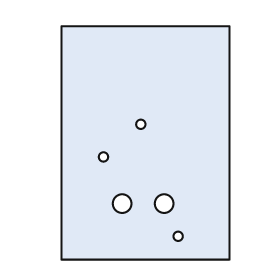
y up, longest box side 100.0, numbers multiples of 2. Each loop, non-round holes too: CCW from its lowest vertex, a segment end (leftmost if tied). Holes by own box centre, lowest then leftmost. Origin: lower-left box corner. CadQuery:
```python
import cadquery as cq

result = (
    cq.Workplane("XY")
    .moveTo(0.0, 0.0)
    .lineTo(72.0, 0.0)
    .lineTo(72.0, 100.0)
    .lineTo(0.0, 100.0)
    .close()
    .moveTo(50.0, 10.0)
    .circle(2.0)
    .moveTo(26.0, 24.0)
    .circle(4.0)
    .moveTo(44.0, 24.0)
    .circle(4.0)
    .moveTo(18.0, 44.0)
    .circle(2.0)
    .moveTo(34.0, 58.0)
    .circle(2.0)
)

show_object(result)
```